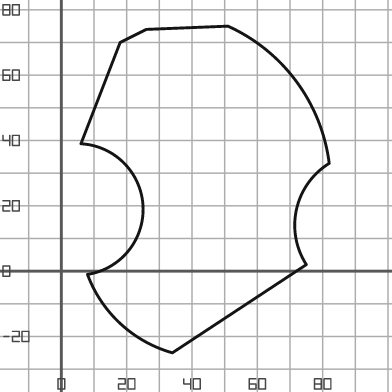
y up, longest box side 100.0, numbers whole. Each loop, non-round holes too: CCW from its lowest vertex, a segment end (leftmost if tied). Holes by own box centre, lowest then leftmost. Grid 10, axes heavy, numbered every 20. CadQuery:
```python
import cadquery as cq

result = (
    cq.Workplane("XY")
    .moveTo(34.0, -25.0)
    .lineTo(75.0, 2.0)
    .threePointArc((72.0, 19.0), (82.0, 33.0))
    .threePointArc((72.0, 58.0), (51.0, 75.0))
    .lineTo(26.0, 74.0)
    .lineTo(18.0, 70.0)
    .lineTo(6.0, 39.0)
    .threePointArc((25.0, 20.0), (8.0, -1.0))
    .threePointArc((18.0, -16.0), (34.0, -25.0))
    .close()
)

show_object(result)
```